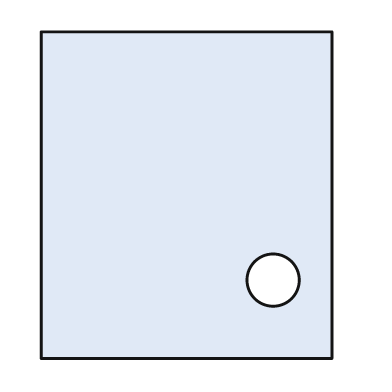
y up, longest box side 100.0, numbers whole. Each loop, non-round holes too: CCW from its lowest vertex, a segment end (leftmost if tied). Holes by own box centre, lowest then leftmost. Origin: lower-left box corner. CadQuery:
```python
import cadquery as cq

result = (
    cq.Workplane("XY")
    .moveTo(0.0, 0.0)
    .lineTo(89.0, 0.0)
    .lineTo(89.0, 100.0)
    .lineTo(0.0, 100.0)
    .close()
    .moveTo(71.0, 24.0)
    .circle(8.0)
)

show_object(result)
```